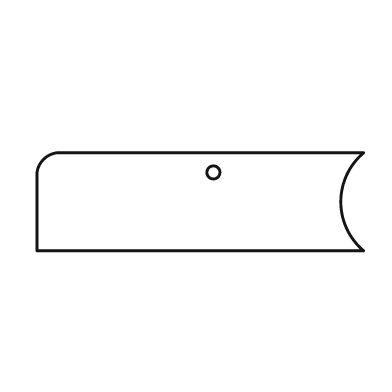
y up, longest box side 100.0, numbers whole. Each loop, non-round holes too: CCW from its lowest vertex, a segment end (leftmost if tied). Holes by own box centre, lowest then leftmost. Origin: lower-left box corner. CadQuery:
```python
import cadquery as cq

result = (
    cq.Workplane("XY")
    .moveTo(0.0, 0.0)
    .lineTo(100.0, 0.0)
    .threePointArc((93.0, 15.0), (100.0, 30.0))
    .lineTo(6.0, 30.0)
    .threePointArc((2.0, 28.0), (0.0, 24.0))
    .close()
    .moveTo(54.0, 24.0)
    .circle(2.0)
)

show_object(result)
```